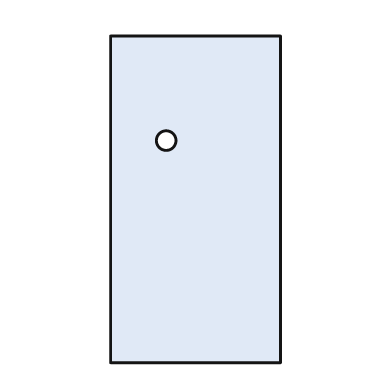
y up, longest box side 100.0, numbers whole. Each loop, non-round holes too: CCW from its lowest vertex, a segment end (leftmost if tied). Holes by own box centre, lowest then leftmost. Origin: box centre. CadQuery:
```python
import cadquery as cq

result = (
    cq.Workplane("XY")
    .moveTo(-26.0, -50.0)
    .lineTo(26.0, -50.0)
    .lineTo(26.0, 50.0)
    .lineTo(-26.0, 50.0)
    .close()
    .moveTo(-9.0, 18.0)
    .circle(3.0)
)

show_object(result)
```